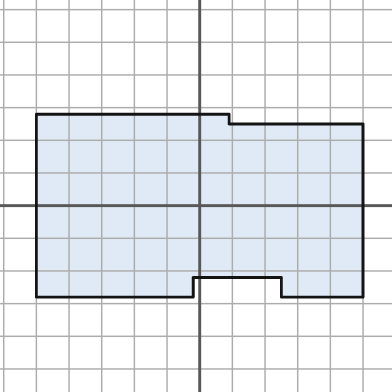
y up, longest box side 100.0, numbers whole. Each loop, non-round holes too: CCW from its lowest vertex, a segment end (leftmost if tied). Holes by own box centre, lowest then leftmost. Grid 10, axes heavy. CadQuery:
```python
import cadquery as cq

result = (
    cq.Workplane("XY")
    .moveTo(-50.0, -28.0)
    .lineTo(-2.0, -28.0)
    .lineTo(-2.0, -22.0)
    .lineTo(25.0, -22.0)
    .lineTo(25.0, -28.0)
    .lineTo(50.0, -28.0)
    .lineTo(50.0, 25.0)
    .lineTo(9.0, 25.0)
    .lineTo(9.0, 28.0)
    .lineTo(-50.0, 28.0)
    .close()
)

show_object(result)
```